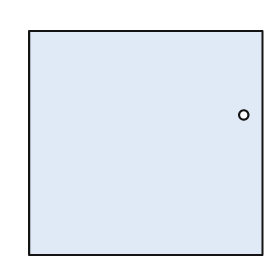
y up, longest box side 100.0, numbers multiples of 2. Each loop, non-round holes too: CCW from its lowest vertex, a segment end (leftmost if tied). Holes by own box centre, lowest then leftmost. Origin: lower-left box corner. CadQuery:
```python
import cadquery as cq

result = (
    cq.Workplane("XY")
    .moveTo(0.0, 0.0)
    .lineTo(100.0, 0.0)
    .lineTo(100.0, 96.0)
    .lineTo(0.0, 96.0)
    .close()
    .moveTo(92.0, 60.0)
    .circle(2.0)
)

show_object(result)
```